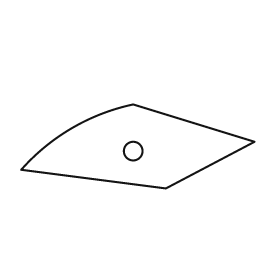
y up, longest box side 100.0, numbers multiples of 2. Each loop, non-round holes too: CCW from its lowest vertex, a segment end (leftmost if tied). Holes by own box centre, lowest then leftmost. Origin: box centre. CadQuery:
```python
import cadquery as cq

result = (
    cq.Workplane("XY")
    .moveTo(12.0, -18.0)
    .lineTo(50.0, 2.0)
    .lineTo(-2.0, 18.0)
    .threePointArc((-28.0, 8.0), (-50.0, -10.0))
    .close()
    .moveTo(-2.0, -2.0)
    .circle(4.0)
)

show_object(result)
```